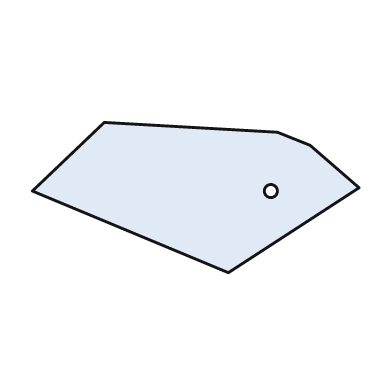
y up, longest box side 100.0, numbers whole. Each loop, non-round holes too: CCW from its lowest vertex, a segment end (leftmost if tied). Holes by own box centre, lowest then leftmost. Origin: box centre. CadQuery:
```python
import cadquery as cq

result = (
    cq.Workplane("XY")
    .moveTo(10.0, -23.0)
    .lineTo(50.0, 3.0)
    .lineTo(35.0, 16.0)
    .lineTo(25.0, 20.0)
    .lineTo(-28.0, 23.0)
    .lineTo(-50.0, 2.0)
    .close()
    .moveTo(23.0, 2.0)
    .circle(2.0)
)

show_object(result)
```